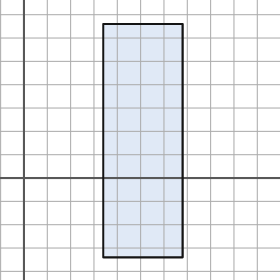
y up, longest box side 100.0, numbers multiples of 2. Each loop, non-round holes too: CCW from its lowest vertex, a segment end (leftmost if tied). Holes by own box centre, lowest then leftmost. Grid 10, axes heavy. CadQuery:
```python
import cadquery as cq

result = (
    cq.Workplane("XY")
    .moveTo(34.0, -34.0)
    .lineTo(68.0, -34.0)
    .lineTo(68.0, 66.0)
    .lineTo(34.0, 66.0)
    .close()
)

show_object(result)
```